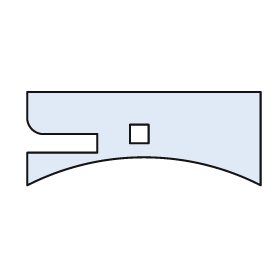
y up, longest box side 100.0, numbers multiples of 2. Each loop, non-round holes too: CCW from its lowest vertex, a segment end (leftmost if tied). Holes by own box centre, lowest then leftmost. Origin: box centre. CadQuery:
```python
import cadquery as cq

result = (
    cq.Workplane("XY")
    .moveTo(-50.0, -20.0)
    .threePointArc((0.0, -8.0), (50.0, -20.0))
    .lineTo(50.0, 20.0)
    .lineTo(-50.0, 20.0)
    .lineTo(-50.0, 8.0)
    .threePointArc((-48.0, 4.0), (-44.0, 2.0))
    .lineTo(-20.0, 2.0)
    .lineTo(-20.0, -6.0)
    .lineTo(-50.0, -6.0)
    .close()
    .moveTo(-6.0, -2.0)
    .lineTo(2.0, -2.0)
    .lineTo(2.0, 6.0)
    .lineTo(-6.0, 6.0)
    .close()
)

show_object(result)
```